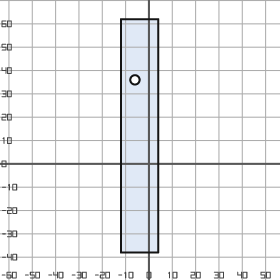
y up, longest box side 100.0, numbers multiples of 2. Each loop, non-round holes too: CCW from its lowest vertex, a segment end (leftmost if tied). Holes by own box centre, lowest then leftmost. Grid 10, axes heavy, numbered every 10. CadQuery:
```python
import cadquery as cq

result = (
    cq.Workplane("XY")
    .moveTo(-12.0, -38.0)
    .lineTo(4.0, -38.0)
    .lineTo(4.0, 62.0)
    .lineTo(-12.0, 62.0)
    .close()
    .moveTo(-6.0, 36.0)
    .circle(2.0)
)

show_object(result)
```